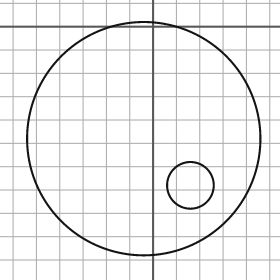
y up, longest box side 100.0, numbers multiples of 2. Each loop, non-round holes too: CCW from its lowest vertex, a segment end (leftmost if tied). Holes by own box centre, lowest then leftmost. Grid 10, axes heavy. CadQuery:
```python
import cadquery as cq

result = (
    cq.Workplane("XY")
    .moveTo(-4.0, -48.0)
    .circle(50.0)
    .moveTo(16.0, -68.0)
    .circle(10.0)
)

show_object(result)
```